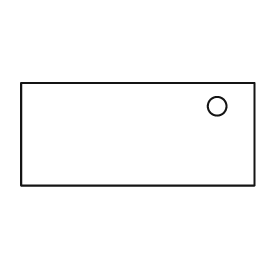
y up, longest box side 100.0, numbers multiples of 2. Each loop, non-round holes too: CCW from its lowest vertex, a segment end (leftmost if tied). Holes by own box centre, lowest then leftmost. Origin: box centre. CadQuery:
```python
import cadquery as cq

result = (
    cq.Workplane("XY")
    .moveTo(-50.0, -22.0)
    .lineTo(50.0, -22.0)
    .lineTo(50.0, 22.0)
    .lineTo(-50.0, 22.0)
    .close()
    .moveTo(34.0, 12.0)
    .circle(4.0)
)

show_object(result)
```